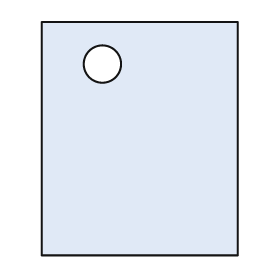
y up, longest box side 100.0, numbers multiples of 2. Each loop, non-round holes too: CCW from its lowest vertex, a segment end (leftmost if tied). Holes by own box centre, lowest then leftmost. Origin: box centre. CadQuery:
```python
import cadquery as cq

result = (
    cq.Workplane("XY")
    .moveTo(-42.0, -50.0)
    .lineTo(42.0, -50.0)
    .lineTo(42.0, 50.0)
    .lineTo(-42.0, 50.0)
    .close()
    .moveTo(-16.0, 32.0)
    .circle(8.0)
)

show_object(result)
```